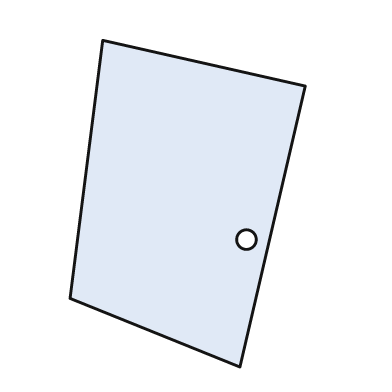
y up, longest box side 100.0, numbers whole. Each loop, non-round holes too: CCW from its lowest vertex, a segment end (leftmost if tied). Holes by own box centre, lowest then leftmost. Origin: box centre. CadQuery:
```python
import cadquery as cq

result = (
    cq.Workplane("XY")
    .moveTo(16.0, -50.0)
    .lineTo(36.0, 36.0)
    .lineTo(-26.0, 50.0)
    .lineTo(-36.0, -29.0)
    .close()
    .moveTo(18.0, -11.0)
    .circle(3.0)
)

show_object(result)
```